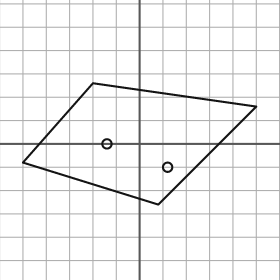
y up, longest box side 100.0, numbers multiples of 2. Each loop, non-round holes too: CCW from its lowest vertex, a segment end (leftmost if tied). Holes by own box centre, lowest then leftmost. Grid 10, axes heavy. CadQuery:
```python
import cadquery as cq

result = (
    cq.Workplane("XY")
    .moveTo(8.0, -26.0)
    .lineTo(50.0, 16.0)
    .lineTo(-20.0, 26.0)
    .lineTo(-50.0, -8.0)
    .close()
    .moveTo(12.0, -10.0)
    .circle(2.0)
    .moveTo(-14.0, 0.0)
    .circle(2.0)
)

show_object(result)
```